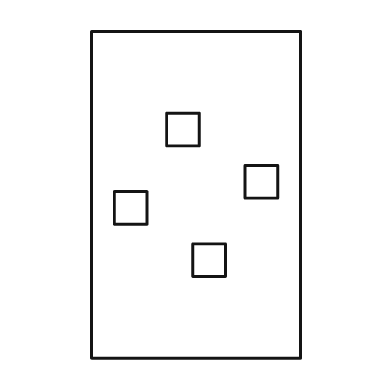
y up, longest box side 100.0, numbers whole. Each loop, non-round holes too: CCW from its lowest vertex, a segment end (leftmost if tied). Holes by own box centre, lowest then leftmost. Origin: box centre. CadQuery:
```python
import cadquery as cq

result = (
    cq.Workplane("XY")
    .moveTo(-32.0, -50.0)
    .lineTo(32.0, -50.0)
    .lineTo(32.0, 50.0)
    .lineTo(-32.0, 50.0)
    .close()
    .moveTo(-1.0, -25.0)
    .lineTo(9.0, -25.0)
    .lineTo(9.0, -15.0)
    .lineTo(-1.0, -15.0)
    .close()
    .moveTo(-25.0, -9.0)
    .lineTo(-15.0, -9.0)
    .lineTo(-15.0, 1.0)
    .lineTo(-25.0, 1.0)
    .close()
    .moveTo(15.0, -1.0)
    .lineTo(25.0, -1.0)
    .lineTo(25.0, 9.0)
    .lineTo(15.0, 9.0)
    .close()
    .moveTo(-9.0, 15.0)
    .lineTo(1.0, 15.0)
    .lineTo(1.0, 25.0)
    .lineTo(-9.0, 25.0)
    .close()
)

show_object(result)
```